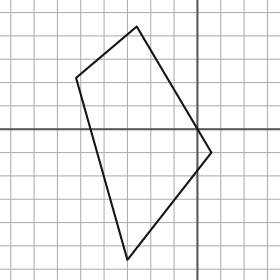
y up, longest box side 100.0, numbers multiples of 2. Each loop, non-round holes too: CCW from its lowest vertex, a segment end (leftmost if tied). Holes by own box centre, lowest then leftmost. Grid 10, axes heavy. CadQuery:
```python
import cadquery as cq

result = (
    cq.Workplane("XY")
    .moveTo(-30.0, -56.0)
    .lineTo(6.0, -10.0)
    .lineTo(-26.0, 44.0)
    .lineTo(-52.0, 22.0)
    .close()
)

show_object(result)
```